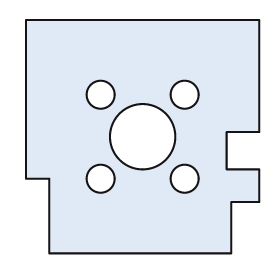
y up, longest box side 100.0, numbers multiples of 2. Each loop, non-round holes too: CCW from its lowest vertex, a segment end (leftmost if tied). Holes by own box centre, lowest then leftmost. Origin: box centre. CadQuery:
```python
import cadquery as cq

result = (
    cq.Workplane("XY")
    .moveTo(-40.0, -50.0)
    .lineTo(38.0, -50.0)
    .lineTo(38.0, -28.0)
    .lineTo(50.0, -28.0)
    .lineTo(50.0, -14.0)
    .lineTo(36.0, -14.0)
    .lineTo(36.0, 2.0)
    .lineTo(50.0, 2.0)
    .lineTo(50.0, 50.0)
    .lineTo(-50.0, 50.0)
    .lineTo(-50.0, -18.0)
    .lineTo(-40.0, -18.0)
    .close()
    .moveTo(-18.0, -18.0)
    .circle(6.0)
    .moveTo(18.0, -18.0)
    .circle(6.0)
    .moveTo(0.0, 0.0)
    .circle(14.0)
    .moveTo(-18.0, 18.0)
    .circle(6.0)
    .moveTo(18.0, 18.0)
    .circle(6.0)
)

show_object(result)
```